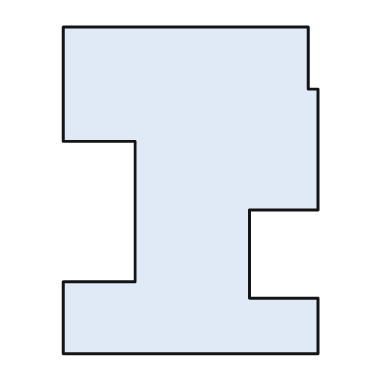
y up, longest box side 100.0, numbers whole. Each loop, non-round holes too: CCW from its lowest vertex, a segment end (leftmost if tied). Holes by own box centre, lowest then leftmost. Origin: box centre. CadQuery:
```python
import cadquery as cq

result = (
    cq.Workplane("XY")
    .moveTo(-39.0, -50.0)
    .lineTo(39.0, -50.0)
    .lineTo(39.0, -33.0)
    .lineTo(18.0, -33.0)
    .lineTo(18.0, -6.0)
    .lineTo(39.0, -6.0)
    .lineTo(39.0, 31.0)
    .lineTo(36.0, 31.0)
    .lineTo(36.0, 50.0)
    .lineTo(-39.0, 50.0)
    .lineTo(-39.0, 15.0)
    .lineTo(-17.0, 15.0)
    .lineTo(-17.0, -28.0)
    .lineTo(-39.0, -28.0)
    .close()
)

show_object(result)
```